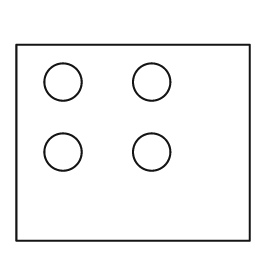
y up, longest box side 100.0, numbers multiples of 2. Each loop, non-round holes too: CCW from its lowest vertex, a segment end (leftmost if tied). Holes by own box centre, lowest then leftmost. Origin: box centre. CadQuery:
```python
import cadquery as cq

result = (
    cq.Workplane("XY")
    .moveTo(-50.0, -42.0)
    .lineTo(50.0, -42.0)
    .lineTo(50.0, 42.0)
    .lineTo(-50.0, 42.0)
    .close()
    .moveTo(-30.0, -4.0)
    .circle(8.0)
    .moveTo(8.0, -4.0)
    .circle(8.0)
    .moveTo(-30.0, 26.0)
    .circle(8.0)
    .moveTo(8.0, 26.0)
    .circle(8.0)
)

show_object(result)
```